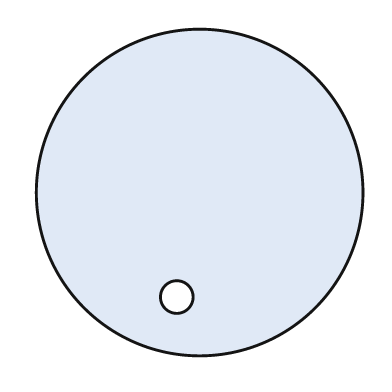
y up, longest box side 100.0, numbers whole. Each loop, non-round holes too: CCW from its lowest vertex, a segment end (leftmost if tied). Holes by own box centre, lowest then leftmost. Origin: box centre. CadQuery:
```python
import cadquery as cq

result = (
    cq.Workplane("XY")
    .moveTo(0.0, 0.0)
    .circle(50.0)
    .moveTo(-7.0, -32.0)
    .circle(5.0)
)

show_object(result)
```